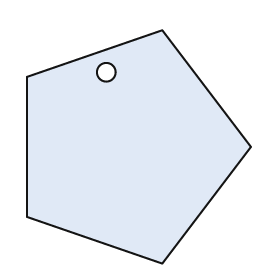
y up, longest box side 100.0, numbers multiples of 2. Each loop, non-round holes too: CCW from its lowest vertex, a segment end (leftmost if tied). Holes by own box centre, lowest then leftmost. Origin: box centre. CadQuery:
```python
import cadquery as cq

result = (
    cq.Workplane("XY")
    .moveTo(10.0, -50.0)
    .lineTo(48.0, 0.0)
    .lineTo(10.0, 50.0)
    .lineTo(-48.0, 30.0)
    .lineTo(-48.0, -30.0)
    .close()
    .moveTo(-14.0, 32.0)
    .circle(4.0)
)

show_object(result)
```